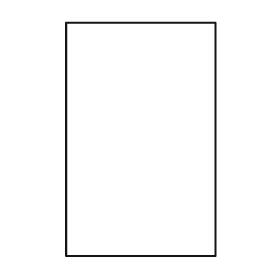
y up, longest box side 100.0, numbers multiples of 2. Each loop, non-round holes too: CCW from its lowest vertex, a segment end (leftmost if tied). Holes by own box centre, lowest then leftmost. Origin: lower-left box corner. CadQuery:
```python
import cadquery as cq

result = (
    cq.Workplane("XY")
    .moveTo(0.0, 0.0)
    .lineTo(64.0, 0.0)
    .lineTo(64.0, 100.0)
    .lineTo(0.0, 100.0)
    .close()
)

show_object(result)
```